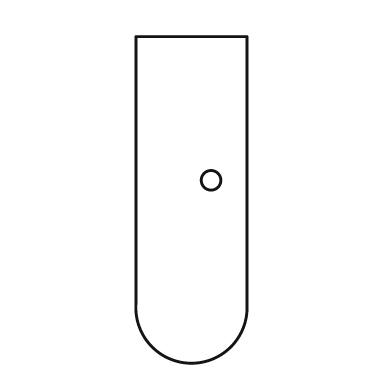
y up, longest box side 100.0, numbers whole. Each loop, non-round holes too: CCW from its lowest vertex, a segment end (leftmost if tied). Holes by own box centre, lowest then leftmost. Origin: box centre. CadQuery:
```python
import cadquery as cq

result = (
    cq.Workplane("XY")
    .moveTo(-17.0, -32.0)
    .threePointArc((0.0, -50.0), (17.0, -32.0))
    .lineTo(17.0, 50.0)
    .lineTo(-17.0, 50.0)
    .close()
    .moveTo(6.0, 6.0)
    .circle(3.0)
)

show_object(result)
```